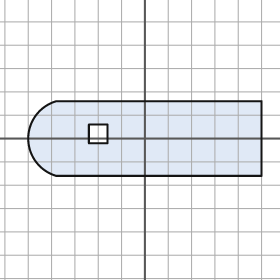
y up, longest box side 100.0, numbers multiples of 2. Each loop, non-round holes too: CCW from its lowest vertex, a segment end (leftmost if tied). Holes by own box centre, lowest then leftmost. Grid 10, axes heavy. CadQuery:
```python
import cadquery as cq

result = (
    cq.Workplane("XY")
    .moveTo(-38.0, -16.0)
    .lineTo(50.0, -16.0)
    .lineTo(50.0, 16.0)
    .lineTo(-38.0, 16.0)
    .threePointArc((-50.0, 0.0), (-38.0, -16.0))
    .close()
    .moveTo(-24.0, -2.0)
    .lineTo(-16.0, -2.0)
    .lineTo(-16.0, 6.0)
    .lineTo(-24.0, 6.0)
    .close()
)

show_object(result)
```